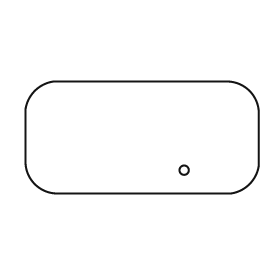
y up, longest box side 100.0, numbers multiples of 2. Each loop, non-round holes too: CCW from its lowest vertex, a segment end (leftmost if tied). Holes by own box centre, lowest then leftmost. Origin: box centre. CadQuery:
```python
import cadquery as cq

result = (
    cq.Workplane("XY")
    .moveTo(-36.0, -24.0)
    .lineTo(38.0, -24.0)
    .threePointArc((46.0, -20.0), (50.0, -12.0))
    .lineTo(50.0, 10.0)
    .threePointArc((46.0, 20.0), (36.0, 24.0))
    .lineTo(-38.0, 24.0)
    .threePointArc((-46.0, 20.0), (-50.0, 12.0))
    .lineTo(-50.0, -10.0)
    .threePointArc((-46.0, -20.0), (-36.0, -24.0))
    .close()
    .moveTo(18.0, -14.0)
    .circle(2.0)
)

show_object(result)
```